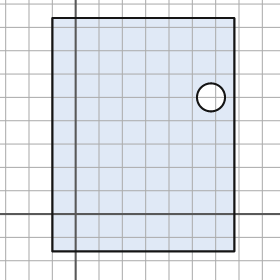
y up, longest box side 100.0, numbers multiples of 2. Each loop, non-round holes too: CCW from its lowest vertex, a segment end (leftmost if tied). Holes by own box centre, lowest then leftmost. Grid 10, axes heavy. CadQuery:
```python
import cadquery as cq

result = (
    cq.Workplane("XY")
    .moveTo(-10.0, -16.0)
    .lineTo(68.0, -16.0)
    .lineTo(68.0, 84.0)
    .lineTo(-10.0, 84.0)
    .close()
    .moveTo(58.0, 50.0)
    .circle(6.0)
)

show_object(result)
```